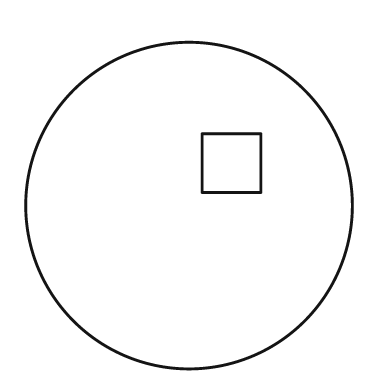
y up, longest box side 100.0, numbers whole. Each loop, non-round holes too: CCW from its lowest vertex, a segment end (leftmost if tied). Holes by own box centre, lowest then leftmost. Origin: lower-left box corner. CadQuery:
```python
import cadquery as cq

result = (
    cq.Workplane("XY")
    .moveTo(50.0, 50.0)
    .circle(50.0)
    .moveTo(54.0, 54.0)
    .lineTo(72.0, 54.0)
    .lineTo(72.0, 72.0)
    .lineTo(54.0, 72.0)
    .close()
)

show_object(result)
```